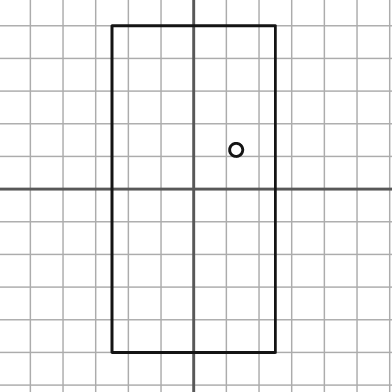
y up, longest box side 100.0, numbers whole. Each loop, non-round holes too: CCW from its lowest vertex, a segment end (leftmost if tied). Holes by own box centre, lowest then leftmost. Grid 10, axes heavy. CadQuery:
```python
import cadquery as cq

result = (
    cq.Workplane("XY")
    .moveTo(-25.0, -50.0)
    .lineTo(25.0, -50.0)
    .lineTo(25.0, 50.0)
    .lineTo(-25.0, 50.0)
    .close()
    .moveTo(13.0, 12.0)
    .circle(2.0)
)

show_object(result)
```